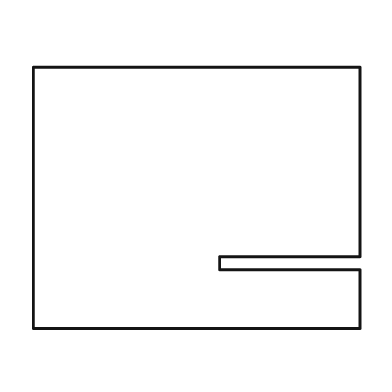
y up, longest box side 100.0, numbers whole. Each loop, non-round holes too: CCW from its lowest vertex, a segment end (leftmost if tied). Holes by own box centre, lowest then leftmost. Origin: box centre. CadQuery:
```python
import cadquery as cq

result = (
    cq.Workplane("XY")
    .moveTo(-50.0, -40.0)
    .lineTo(50.0, -40.0)
    .lineTo(50.0, -22.0)
    .lineTo(7.0, -22.0)
    .lineTo(7.0, -18.0)
    .lineTo(50.0, -18.0)
    .lineTo(50.0, 40.0)
    .lineTo(-50.0, 40.0)
    .close()
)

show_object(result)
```